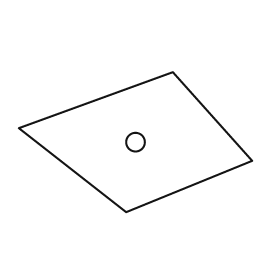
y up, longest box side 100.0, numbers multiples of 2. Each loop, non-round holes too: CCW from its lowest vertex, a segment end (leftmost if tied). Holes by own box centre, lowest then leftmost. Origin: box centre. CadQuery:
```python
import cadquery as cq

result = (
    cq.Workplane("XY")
    .moveTo(-4.0, -30.0)
    .lineTo(50.0, -8.0)
    .lineTo(16.0, 30.0)
    .lineTo(-50.0, 6.0)
    .close()
    .moveTo(0.0, 0.0)
    .circle(4.0)
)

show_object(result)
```